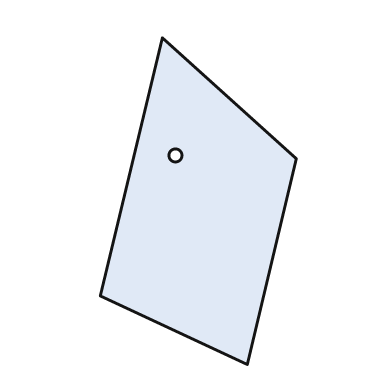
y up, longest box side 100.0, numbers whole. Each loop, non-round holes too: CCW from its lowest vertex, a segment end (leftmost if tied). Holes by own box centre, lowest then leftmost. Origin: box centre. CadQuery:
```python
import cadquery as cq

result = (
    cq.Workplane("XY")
    .moveTo(15.0, -50.0)
    .lineTo(30.0, 13.0)
    .lineTo(-11.0, 50.0)
    .lineTo(-30.0, -29.0)
    .close()
    .moveTo(-7.0, 14.0)
    .circle(2.0)
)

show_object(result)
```